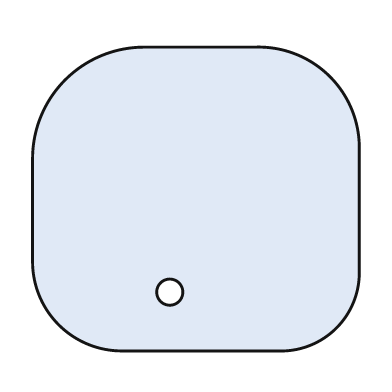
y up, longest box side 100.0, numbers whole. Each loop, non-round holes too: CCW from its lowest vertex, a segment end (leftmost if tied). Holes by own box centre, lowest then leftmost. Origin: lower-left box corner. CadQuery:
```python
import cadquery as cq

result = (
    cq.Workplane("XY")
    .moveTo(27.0, 0.0)
    .lineTo(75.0, 0.0)
    .threePointArc((93.0, 7.0), (100.0, 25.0))
    .lineTo(100.0, 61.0)
    .threePointArc((91.0, 84.0), (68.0, 93.0))
    .lineTo(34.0, 93.0)
    .threePointArc((10.0, 83.0), (0.0, 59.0))
    .lineTo(0.0, 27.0)
    .threePointArc((8.0, 8.0), (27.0, 0.0))
    .close()
    .moveTo(42.0, 18.0)
    .circle(4.0)
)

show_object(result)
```